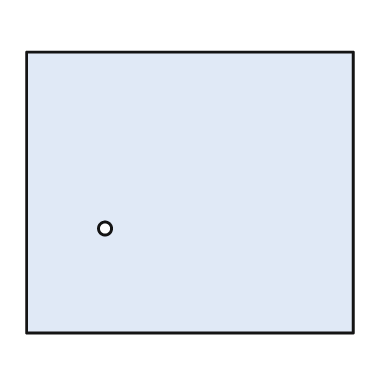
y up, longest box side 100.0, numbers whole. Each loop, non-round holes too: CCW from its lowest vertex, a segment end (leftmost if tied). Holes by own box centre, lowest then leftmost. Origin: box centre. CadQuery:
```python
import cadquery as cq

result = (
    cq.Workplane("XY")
    .moveTo(-50.0, -43.0)
    .lineTo(50.0, -43.0)
    .lineTo(50.0, 43.0)
    .lineTo(-50.0, 43.0)
    .close()
    .moveTo(-26.0, -11.0)
    .circle(2.0)
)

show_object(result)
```